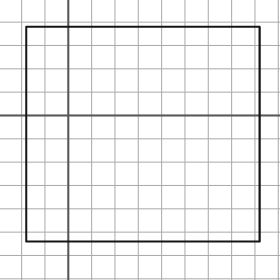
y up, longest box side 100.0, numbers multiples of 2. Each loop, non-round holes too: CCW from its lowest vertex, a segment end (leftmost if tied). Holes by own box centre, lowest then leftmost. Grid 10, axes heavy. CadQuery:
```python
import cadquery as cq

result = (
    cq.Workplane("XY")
    .moveTo(-18.0, -54.0)
    .lineTo(82.0, -54.0)
    .lineTo(82.0, 38.0)
    .lineTo(-18.0, 38.0)
    .close()
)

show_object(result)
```